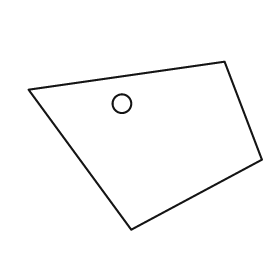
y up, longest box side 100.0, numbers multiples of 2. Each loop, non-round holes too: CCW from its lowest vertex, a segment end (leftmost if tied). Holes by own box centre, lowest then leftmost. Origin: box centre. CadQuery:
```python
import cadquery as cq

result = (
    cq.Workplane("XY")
    .moveTo(-6.0, -36.0)
    .lineTo(50.0, -6.0)
    .lineTo(34.0, 36.0)
    .lineTo(-50.0, 24.0)
    .close()
    .moveTo(-10.0, 18.0)
    .circle(4.0)
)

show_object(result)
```